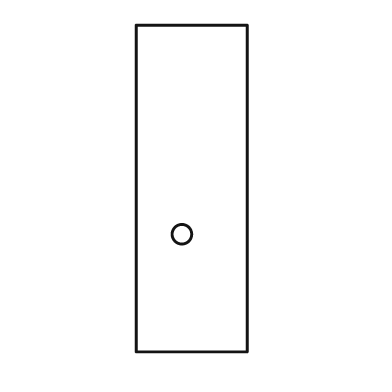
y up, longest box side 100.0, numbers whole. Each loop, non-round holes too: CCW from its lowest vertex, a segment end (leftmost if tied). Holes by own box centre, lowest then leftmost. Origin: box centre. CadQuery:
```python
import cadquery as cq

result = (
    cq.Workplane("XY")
    .moveTo(-17.0, -50.0)
    .lineTo(17.0, -50.0)
    .lineTo(17.0, 50.0)
    .lineTo(-17.0, 50.0)
    .close()
    .moveTo(-3.0, -14.0)
    .circle(3.0)
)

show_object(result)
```